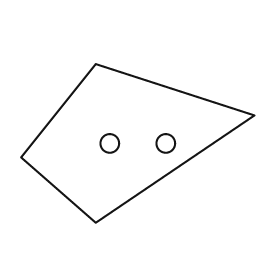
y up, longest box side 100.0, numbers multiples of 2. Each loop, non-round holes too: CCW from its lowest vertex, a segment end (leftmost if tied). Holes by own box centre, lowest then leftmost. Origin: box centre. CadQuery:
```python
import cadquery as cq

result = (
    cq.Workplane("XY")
    .moveTo(-18.0, -34.0)
    .lineTo(50.0, 12.0)
    .lineTo(-18.0, 34.0)
    .lineTo(-50.0, -6.0)
    .close()
    .moveTo(-12.0, 0.0)
    .circle(4.0)
    .moveTo(12.0, 0.0)
    .circle(4.0)
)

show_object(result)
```